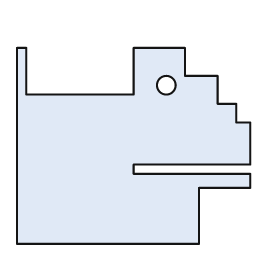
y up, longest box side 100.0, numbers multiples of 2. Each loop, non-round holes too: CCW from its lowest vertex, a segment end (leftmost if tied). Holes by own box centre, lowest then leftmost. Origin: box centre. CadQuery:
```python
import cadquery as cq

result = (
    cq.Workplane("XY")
    .moveTo(-50.0, -42.0)
    .lineTo(28.0, -42.0)
    .lineTo(28.0, -18.0)
    .lineTo(50.0, -18.0)
    .lineTo(50.0, -12.0)
    .lineTo(0.0, -12.0)
    .lineTo(0.0, -8.0)
    .lineTo(50.0, -8.0)
    .lineTo(50.0, 10.0)
    .lineTo(44.0, 10.0)
    .lineTo(44.0, 18.0)
    .lineTo(36.0, 18.0)
    .lineTo(36.0, 30.0)
    .lineTo(22.0, 30.0)
    .lineTo(22.0, 42.0)
    .lineTo(0.0, 42.0)
    .lineTo(0.0, 22.0)
    .lineTo(-46.0, 22.0)
    .lineTo(-46.0, 42.0)
    .lineTo(-50.0, 42.0)
    .close()
    .moveTo(14.0, 26.0)
    .circle(4.0)
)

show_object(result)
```